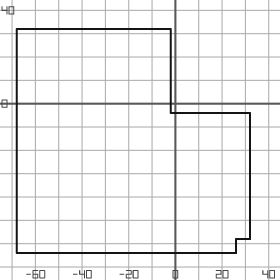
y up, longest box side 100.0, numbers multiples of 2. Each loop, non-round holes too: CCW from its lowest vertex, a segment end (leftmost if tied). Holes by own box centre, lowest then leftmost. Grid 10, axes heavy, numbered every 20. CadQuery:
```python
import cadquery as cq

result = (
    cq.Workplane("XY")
    .moveTo(-68.0, -64.0)
    .lineTo(26.0, -64.0)
    .lineTo(26.0, -58.0)
    .lineTo(32.0, -58.0)
    .lineTo(32.0, -4.0)
    .lineTo(-2.0, -4.0)
    .lineTo(-2.0, 32.0)
    .lineTo(-68.0, 32.0)
    .close()
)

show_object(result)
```